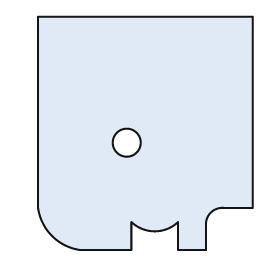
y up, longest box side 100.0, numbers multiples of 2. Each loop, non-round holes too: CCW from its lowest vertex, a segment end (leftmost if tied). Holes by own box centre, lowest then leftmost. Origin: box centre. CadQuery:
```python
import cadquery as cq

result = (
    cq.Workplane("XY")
    .moveTo(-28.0, -50.0)
    .lineTo(-6.0, -50.0)
    .lineTo(-6.0, -38.0)
    .threePointArc((4.0, -42.0), (14.0, -38.0))
    .lineTo(14.0, -50.0)
    .lineTo(26.0, -50.0)
    .lineTo(26.0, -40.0)
    .threePointArc((28.0, -34.0), (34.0, -32.0))
    .lineTo(46.0, -32.0)
    .lineTo(46.0, 50.0)
    .lineTo(-46.0, 50.0)
    .lineTo(-46.0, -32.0)
    .threePointArc((-40.0, -44.0), (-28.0, -50.0))
    .close()
    .moveTo(-8.0, -4.0)
    .circle(6.0)
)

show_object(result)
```